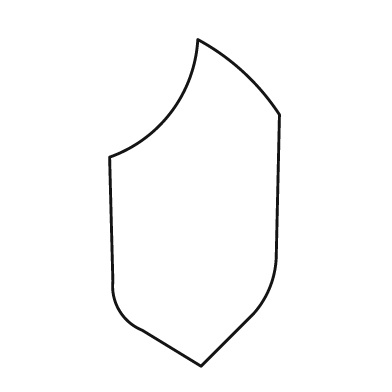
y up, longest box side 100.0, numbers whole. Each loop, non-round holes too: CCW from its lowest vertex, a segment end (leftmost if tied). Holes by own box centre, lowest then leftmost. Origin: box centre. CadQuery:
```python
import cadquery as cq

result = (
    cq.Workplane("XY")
    .moveTo(2.0, -50.0)
    .lineTo(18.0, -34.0)
    .threePointArc((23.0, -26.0), (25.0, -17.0))
    .lineTo(26.0, 27.0)
    .threePointArc((15.0, 40.0), (1.0, 50.0))
    .threePointArc((-7.0, 28.0), (-26.0, 14.0))
    .lineTo(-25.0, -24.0)
    .threePointArc((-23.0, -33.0), (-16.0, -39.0))
    .close()
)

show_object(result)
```